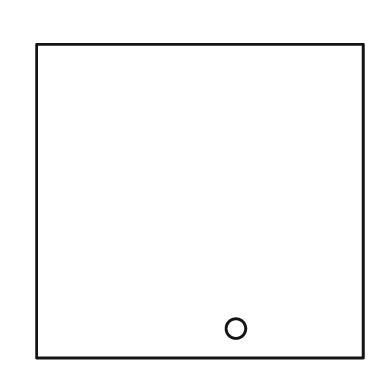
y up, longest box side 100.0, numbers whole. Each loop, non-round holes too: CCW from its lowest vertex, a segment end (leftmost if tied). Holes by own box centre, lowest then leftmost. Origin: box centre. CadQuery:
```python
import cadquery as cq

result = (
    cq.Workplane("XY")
    .moveTo(-50.0, -48.0)
    .lineTo(50.0, -48.0)
    .lineTo(50.0, 48.0)
    .lineTo(-50.0, 48.0)
    .close()
    .moveTo(11.0, -39.0)
    .circle(3.0)
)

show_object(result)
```